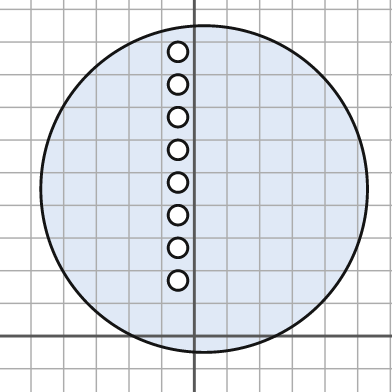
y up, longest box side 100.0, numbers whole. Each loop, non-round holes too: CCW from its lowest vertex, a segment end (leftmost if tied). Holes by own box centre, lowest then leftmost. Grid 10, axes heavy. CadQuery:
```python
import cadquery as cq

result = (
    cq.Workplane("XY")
    .moveTo(3.0, 45.0)
    .circle(50.0)
    .moveTo(-5.0, 17.0)
    .circle(3.0)
    .moveTo(-5.0, 27.0)
    .circle(3.0)
    .moveTo(-5.0, 37.0)
    .circle(3.0)
    .moveTo(-5.0, 47.0)
    .circle(3.0)
    .moveTo(-5.0, 57.0)
    .circle(3.0)
    .moveTo(-5.0, 67.0)
    .circle(3.0)
    .moveTo(-5.0, 77.0)
    .circle(3.0)
    .moveTo(-5.0, 87.0)
    .circle(3.0)
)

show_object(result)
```